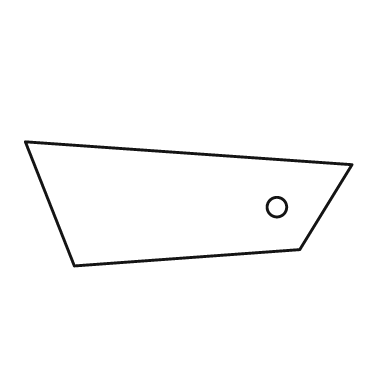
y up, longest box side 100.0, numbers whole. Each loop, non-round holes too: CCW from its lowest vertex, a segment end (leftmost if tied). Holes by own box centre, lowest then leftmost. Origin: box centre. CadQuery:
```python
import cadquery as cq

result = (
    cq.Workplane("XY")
    .moveTo(-35.0, -19.0)
    .lineTo(34.0, -14.0)
    .lineTo(50.0, 12.0)
    .lineTo(-50.0, 19.0)
    .close()
    .moveTo(27.0, -1.0)
    .circle(3.0)
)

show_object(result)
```